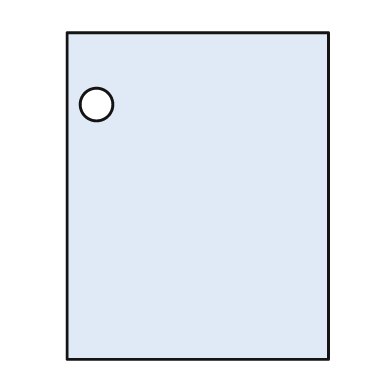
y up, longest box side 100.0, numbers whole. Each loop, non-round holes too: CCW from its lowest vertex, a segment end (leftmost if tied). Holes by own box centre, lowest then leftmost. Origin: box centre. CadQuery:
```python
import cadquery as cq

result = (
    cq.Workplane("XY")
    .moveTo(-40.0, -50.0)
    .lineTo(40.0, -50.0)
    .lineTo(40.0, 50.0)
    .lineTo(-40.0, 50.0)
    .close()
    .moveTo(-31.0, 28.0)
    .circle(5.0)
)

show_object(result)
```